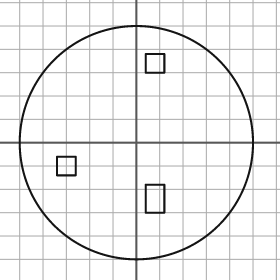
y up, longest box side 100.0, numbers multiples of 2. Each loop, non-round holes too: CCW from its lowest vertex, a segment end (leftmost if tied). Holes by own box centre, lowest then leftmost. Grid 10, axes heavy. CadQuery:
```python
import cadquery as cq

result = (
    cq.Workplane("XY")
    .moveTo(0.0, 0.0)
    .circle(50.0)
    .moveTo(4.0, -30.0)
    .lineTo(12.0, -30.0)
    .lineTo(12.0, -18.0)
    .lineTo(4.0, -18.0)
    .close()
    .moveTo(-34.0, -14.0)
    .lineTo(-26.0, -14.0)
    .lineTo(-26.0, -6.0)
    .lineTo(-34.0, -6.0)
    .close()
    .moveTo(4.0, 30.0)
    .lineTo(12.0, 30.0)
    .lineTo(12.0, 38.0)
    .lineTo(4.0, 38.0)
    .close()
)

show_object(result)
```